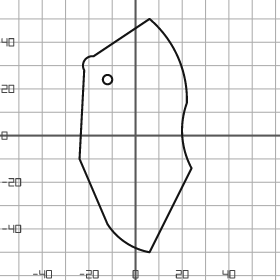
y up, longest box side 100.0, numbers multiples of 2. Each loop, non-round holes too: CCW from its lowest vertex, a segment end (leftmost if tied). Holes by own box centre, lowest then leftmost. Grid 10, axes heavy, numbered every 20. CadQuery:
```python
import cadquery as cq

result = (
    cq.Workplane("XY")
    .moveTo(6.0, -50.0)
    .lineTo(24.0, -14.0)
    .threePointArc((20.0, 0.0), (22.0, 14.0))
    .threePointArc((18.0, 34.0), (6.0, 50.0))
    .lineTo(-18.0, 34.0)
    .threePointArc((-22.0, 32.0), (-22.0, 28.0))
    .lineTo(-24.0, -10.0)
    .lineTo(-12.0, -38.0)
    .threePointArc((-4.0, -46.0), (6.0, -50.0))
    .close()
    .moveTo(-12.0, 24.0)
    .circle(2.0)
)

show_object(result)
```